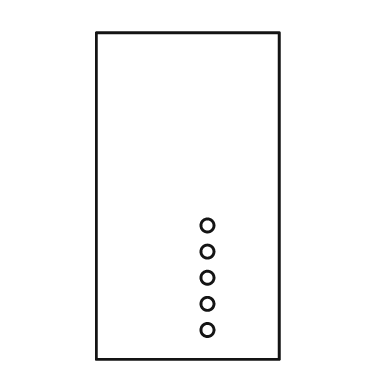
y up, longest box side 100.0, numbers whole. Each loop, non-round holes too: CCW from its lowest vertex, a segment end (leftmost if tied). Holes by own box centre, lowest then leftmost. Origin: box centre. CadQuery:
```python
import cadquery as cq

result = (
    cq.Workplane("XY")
    .moveTo(-28.0, -50.0)
    .lineTo(28.0, -50.0)
    .lineTo(28.0, 50.0)
    .lineTo(-28.0, 50.0)
    .close()
    .moveTo(6.0, -41.0)
    .circle(2.0)
    .moveTo(6.0, -33.0)
    .circle(2.0)
    .moveTo(6.0, -25.0)
    .circle(2.0)
    .moveTo(6.0, -17.0)
    .circle(2.0)
    .moveTo(6.0, -9.0)
    .circle(2.0)
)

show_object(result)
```